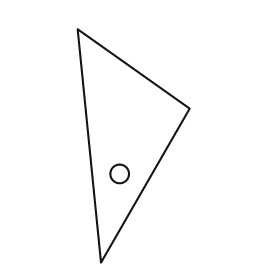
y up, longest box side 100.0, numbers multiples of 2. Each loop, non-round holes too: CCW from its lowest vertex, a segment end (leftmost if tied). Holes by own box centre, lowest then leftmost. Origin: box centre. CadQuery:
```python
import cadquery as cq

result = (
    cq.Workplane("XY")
    .moveTo(-14.0, -50.0)
    .lineTo(24.0, 16.0)
    .lineTo(-24.0, 50.0)
    .close()
    .moveTo(-6.0, -12.0)
    .circle(4.0)
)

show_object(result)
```